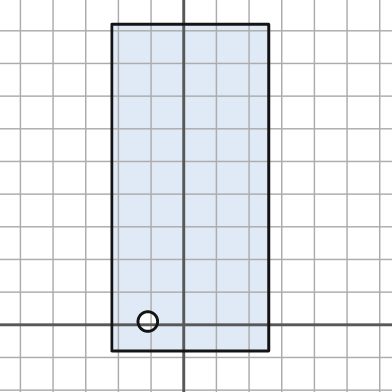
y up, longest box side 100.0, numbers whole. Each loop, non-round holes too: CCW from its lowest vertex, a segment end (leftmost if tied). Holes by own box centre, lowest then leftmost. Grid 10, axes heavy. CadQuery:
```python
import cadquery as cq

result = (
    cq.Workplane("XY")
    .moveTo(-22.0, -8.0)
    .lineTo(26.0, -8.0)
    .lineTo(26.0, 92.0)
    .lineTo(-22.0, 92.0)
    .close()
    .moveTo(-11.0, 1.0)
    .circle(3.0)
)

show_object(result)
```